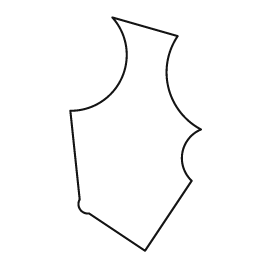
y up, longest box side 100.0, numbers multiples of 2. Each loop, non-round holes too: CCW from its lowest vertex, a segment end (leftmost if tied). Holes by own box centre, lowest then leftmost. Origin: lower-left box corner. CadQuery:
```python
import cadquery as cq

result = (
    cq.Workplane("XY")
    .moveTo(32.0, 0.0)
    .lineTo(52.0, 30.0)
    .threePointArc((48.0, 42.0), (56.0, 52.0))
    .threePointArc((42.0, 70.0), (46.0, 92.0))
    .lineTo(18.0, 100.0)
    .threePointArc((22.0, 74.0), (0.0, 60.0))
    .lineTo(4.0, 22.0)
    .threePointArc((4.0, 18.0), (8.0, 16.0))
    .close()
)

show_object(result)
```